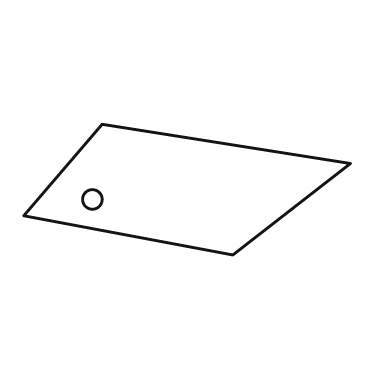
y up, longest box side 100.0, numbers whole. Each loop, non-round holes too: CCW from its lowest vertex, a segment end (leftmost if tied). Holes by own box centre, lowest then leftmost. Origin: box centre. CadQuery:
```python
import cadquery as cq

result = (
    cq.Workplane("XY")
    .moveTo(14.0, -20.0)
    .lineTo(50.0, 8.0)
    .lineTo(-26.0, 20.0)
    .lineTo(-50.0, -8.0)
    .close()
    .moveTo(-29.0, -3.0)
    .circle(3.0)
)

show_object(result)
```